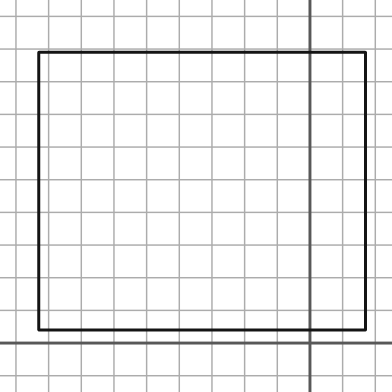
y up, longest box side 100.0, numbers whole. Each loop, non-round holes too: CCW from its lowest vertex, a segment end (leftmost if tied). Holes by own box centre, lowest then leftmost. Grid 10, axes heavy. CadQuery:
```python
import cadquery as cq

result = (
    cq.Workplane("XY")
    .moveTo(-83.0, 4.0)
    .lineTo(17.0, 4.0)
    .lineTo(17.0, 89.0)
    .lineTo(-83.0, 89.0)
    .close()
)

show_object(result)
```